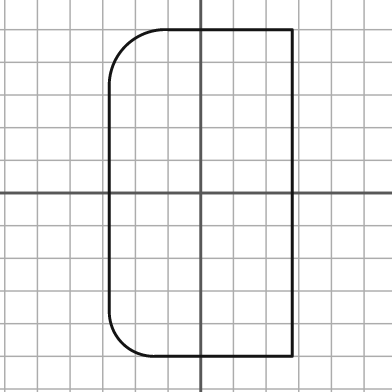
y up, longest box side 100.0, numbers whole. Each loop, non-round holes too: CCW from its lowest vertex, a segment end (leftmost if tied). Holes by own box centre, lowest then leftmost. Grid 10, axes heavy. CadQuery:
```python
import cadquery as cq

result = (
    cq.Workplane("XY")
    .moveTo(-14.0, -50.0)
    .lineTo(28.0, -50.0)
    .lineTo(28.0, 50.0)
    .lineTo(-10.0, 50.0)
    .threePointArc((-23.0, 45.0), (-28.0, 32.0))
    .lineTo(-28.0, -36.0)
    .threePointArc((-24.0, -46.0), (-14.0, -50.0))
    .close()
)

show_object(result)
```